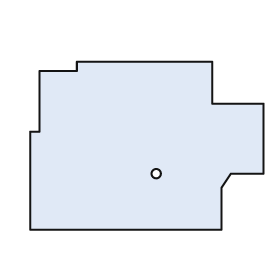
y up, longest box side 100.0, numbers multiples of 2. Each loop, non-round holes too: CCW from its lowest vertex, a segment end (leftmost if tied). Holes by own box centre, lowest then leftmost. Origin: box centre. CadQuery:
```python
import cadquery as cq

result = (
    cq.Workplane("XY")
    .moveTo(-50.0, -36.0)
    .lineTo(32.0, -36.0)
    .lineTo(32.0, -18.0)
    .lineTo(36.0, -12.0)
    .lineTo(50.0, -12.0)
    .lineTo(50.0, 18.0)
    .lineTo(28.0, 18.0)
    .lineTo(28.0, 36.0)
    .lineTo(-30.0, 36.0)
    .lineTo(-30.0, 32.0)
    .lineTo(-46.0, 32.0)
    .lineTo(-46.0, 6.0)
    .lineTo(-50.0, 6.0)
    .close()
    .moveTo(4.0, -12.0)
    .circle(2.0)
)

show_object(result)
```